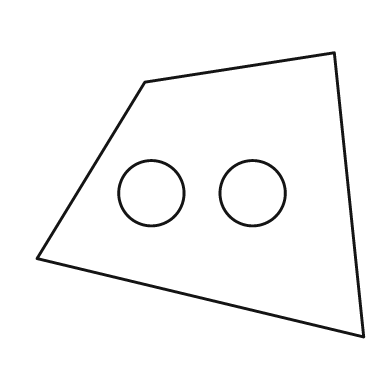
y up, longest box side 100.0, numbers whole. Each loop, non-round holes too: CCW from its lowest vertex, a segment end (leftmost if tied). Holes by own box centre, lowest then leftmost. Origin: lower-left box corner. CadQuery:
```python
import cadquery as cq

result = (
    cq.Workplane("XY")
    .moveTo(100.0, 0.0)
    .lineTo(91.0, 87.0)
    .lineTo(33.0, 78.0)
    .lineTo(0.0, 24.0)
    .close()
    .moveTo(35.0, 44.0)
    .circle(10.0)
    .moveTo(66.0, 44.0)
    .circle(10.0)
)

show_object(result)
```